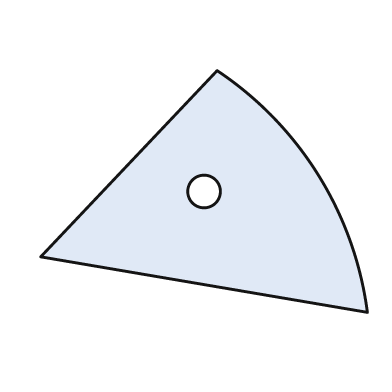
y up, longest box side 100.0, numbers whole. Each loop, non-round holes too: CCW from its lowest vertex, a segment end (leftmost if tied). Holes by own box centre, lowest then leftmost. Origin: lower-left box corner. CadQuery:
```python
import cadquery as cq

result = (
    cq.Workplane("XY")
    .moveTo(100.0, 0.0)
    .threePointArc((85.0, 42.0), (54.0, 74.0))
    .lineTo(0.0, 17.0)
    .close()
    .moveTo(50.0, 37.0)
    .circle(5.0)
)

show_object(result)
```